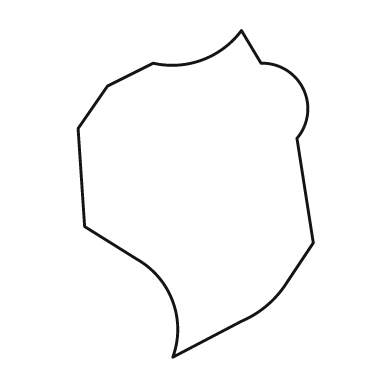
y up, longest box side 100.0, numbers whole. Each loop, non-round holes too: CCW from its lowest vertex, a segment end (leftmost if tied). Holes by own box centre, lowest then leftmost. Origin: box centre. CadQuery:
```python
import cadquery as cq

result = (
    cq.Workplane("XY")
    .moveTo(-7.0, -50.0)
    .lineTo(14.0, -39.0)
    .threePointArc((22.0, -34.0), (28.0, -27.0))
    .lineTo(36.0, -15.0)
    .lineTo(31.0, 17.0)
    .threePointArc((33.0, 32.0), (20.0, 40.0))
    .lineTo(14.0, 50.0)
    .threePointArc((2.0, 41.0), (-13.0, 40.0))
    .lineTo(-27.0, 33.0)
    .lineTo(-36.0, 20.0)
    .lineTo(-34.0, -10.0)
    .lineTo(-18.0, -20.0)
    .threePointArc((-7.0, -33.0), (-7.0, -50.0))
    .close()
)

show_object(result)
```